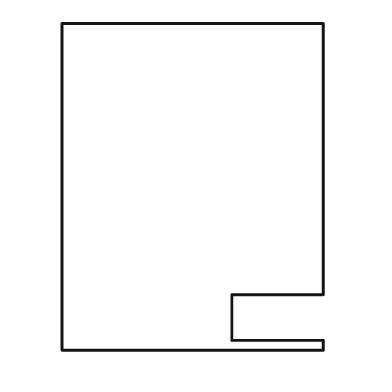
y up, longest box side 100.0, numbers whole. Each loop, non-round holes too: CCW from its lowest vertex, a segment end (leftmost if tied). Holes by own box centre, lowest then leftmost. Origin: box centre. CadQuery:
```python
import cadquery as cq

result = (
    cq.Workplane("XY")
    .moveTo(-40.0, -50.0)
    .lineTo(40.0, -50.0)
    .lineTo(40.0, -47.0)
    .lineTo(12.0, -47.0)
    .lineTo(12.0, -33.0)
    .lineTo(40.0, -33.0)
    .lineTo(40.0, 50.0)
    .lineTo(-40.0, 50.0)
    .close()
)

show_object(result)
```